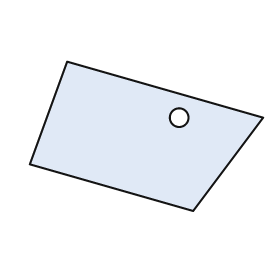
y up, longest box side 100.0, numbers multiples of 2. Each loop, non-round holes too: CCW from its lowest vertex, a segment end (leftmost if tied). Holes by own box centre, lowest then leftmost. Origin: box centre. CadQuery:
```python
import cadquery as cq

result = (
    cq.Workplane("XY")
    .moveTo(20.0, -32.0)
    .lineTo(50.0, 8.0)
    .lineTo(-34.0, 32.0)
    .lineTo(-50.0, -12.0)
    .close()
    .moveTo(14.0, 8.0)
    .circle(4.0)
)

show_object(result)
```